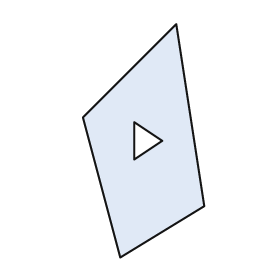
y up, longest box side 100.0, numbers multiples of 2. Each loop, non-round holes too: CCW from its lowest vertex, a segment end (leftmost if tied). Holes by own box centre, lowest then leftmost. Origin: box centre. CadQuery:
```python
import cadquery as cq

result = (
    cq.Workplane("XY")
    .moveTo(-10.0, -50.0)
    .lineTo(26.0, -28.0)
    .lineTo(14.0, 50.0)
    .lineTo(-26.0, 10.0)
    .close()
    .moveTo(-4.0, -8.0)
    .lineTo(8.0, 0.0)
    .lineTo(-4.0, 8.0)
    .close()
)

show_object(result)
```